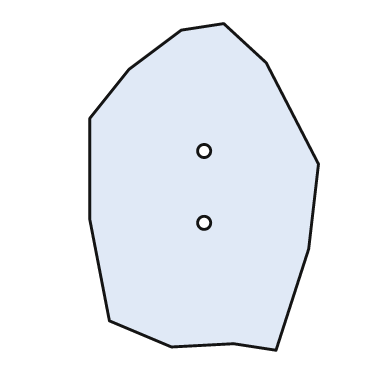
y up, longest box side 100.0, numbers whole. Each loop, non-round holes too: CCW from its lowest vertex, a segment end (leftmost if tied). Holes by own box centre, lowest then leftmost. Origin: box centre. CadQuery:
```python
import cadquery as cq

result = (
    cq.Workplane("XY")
    .moveTo(22.0, -50.0)
    .lineTo(32.0, -19.0)
    .lineTo(35.0, 7.0)
    .lineTo(19.0, 38.0)
    .lineTo(6.0, 50.0)
    .lineTo(-7.0, 48.0)
    .lineTo(-23.0, 36.0)
    .lineTo(-35.0, 21.0)
    .lineTo(-35.0, -10.0)
    .lineTo(-29.0, -41.0)
    .lineTo(-10.0, -49.0)
    .lineTo(9.0, -48.0)
    .close()
    .moveTo(0.0, -11.0)
    .circle(2.0)
    .moveTo(0.0, 11.0)
    .circle(2.0)
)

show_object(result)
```